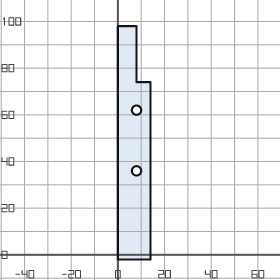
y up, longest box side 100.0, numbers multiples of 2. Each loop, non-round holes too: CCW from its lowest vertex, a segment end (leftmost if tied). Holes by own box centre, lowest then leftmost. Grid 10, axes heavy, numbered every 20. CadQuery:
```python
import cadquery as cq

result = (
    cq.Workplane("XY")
    .moveTo(0.0, -2.0)
    .lineTo(14.0, -2.0)
    .lineTo(14.0, 74.0)
    .lineTo(8.0, 74.0)
    .lineTo(8.0, 98.0)
    .lineTo(0.0, 98.0)
    .close()
    .moveTo(8.0, 36.0)
    .circle(2.0)
    .moveTo(8.0, 62.0)
    .circle(2.0)
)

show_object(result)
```